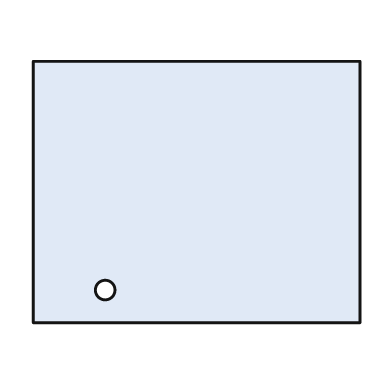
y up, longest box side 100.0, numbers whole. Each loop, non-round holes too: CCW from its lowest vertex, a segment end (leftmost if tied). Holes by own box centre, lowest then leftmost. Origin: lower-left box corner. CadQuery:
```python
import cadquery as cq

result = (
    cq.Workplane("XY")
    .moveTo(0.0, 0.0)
    .lineTo(100.0, 0.0)
    .lineTo(100.0, 80.0)
    .lineTo(0.0, 80.0)
    .close()
    .moveTo(22.0, 10.0)
    .circle(3.0)
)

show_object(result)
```